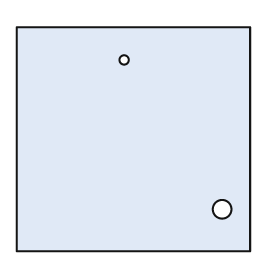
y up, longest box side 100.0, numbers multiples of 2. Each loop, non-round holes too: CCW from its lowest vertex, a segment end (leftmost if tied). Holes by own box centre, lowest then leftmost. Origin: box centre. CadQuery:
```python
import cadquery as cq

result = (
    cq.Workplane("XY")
    .moveTo(-50.0, -48.0)
    .lineTo(50.0, -48.0)
    .lineTo(50.0, 48.0)
    .lineTo(-50.0, 48.0)
    .close()
    .moveTo(38.0, -30.0)
    .circle(4.0)
    .moveTo(-4.0, 34.0)
    .circle(2.0)
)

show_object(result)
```